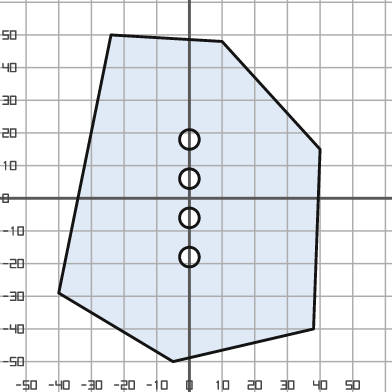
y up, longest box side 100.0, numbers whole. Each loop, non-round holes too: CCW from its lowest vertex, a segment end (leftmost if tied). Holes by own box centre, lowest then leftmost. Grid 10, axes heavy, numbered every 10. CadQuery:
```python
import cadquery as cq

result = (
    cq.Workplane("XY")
    .moveTo(-5.0, -50.0)
    .lineTo(38.0, -40.0)
    .lineTo(40.0, 15.0)
    .lineTo(10.0, 48.0)
    .lineTo(-24.0, 50.0)
    .lineTo(-40.0, -29.0)
    .close()
    .moveTo(0.0, -18.0)
    .circle(3.0)
    .moveTo(0.0, -6.0)
    .circle(3.0)
    .moveTo(0.0, 6.0)
    .circle(3.0)
    .moveTo(0.0, 18.0)
    .circle(3.0)
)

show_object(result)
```